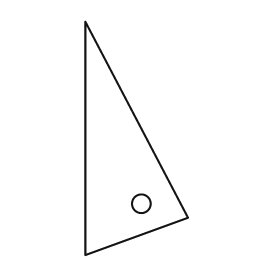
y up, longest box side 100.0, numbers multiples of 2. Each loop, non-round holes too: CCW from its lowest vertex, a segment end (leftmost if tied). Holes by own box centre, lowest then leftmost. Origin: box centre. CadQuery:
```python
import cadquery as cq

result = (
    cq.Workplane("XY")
    .moveTo(-22.0, -50.0)
    .lineTo(22.0, -34.0)
    .lineTo(-22.0, 50.0)
    .close()
    .moveTo(2.0, -28.0)
    .circle(4.0)
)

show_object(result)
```